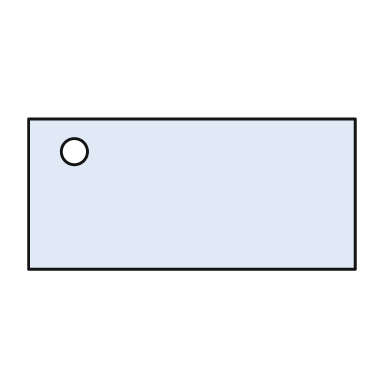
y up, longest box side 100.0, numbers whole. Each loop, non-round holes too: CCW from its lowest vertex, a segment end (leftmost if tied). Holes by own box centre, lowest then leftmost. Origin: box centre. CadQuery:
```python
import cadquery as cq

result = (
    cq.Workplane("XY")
    .moveTo(-50.0, -23.0)
    .lineTo(50.0, -23.0)
    .lineTo(50.0, 23.0)
    .lineTo(-50.0, 23.0)
    .close()
    .moveTo(-36.0, 13.0)
    .circle(4.0)
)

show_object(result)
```